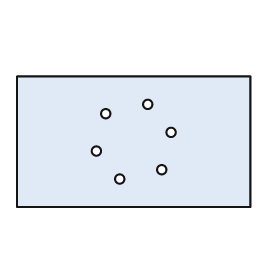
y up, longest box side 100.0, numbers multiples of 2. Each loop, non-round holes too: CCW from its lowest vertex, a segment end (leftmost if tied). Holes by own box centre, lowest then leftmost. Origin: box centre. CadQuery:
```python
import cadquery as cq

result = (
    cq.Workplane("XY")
    .moveTo(-50.0, -28.0)
    .lineTo(50.0, -28.0)
    .lineTo(50.0, 28.0)
    .lineTo(-50.0, 28.0)
    .close()
    .moveTo(-6.0, -16.0)
    .circle(2.0)
    .moveTo(12.0, -12.0)
    .circle(2.0)
    .moveTo(-16.0, -4.0)
    .circle(2.0)
    .moveTo(16.0, 4.0)
    .circle(2.0)
    .moveTo(-12.0, 12.0)
    .circle(2.0)
    .moveTo(6.0, 16.0)
    .circle(2.0)
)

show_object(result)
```